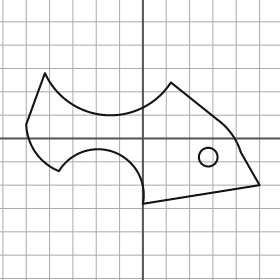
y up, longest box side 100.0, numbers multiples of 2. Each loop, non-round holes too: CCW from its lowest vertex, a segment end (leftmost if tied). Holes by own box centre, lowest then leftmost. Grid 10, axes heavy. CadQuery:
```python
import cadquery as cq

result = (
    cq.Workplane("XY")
    .moveTo(0.0, -28.0)
    .lineTo(50.0, -20.0)
    .lineTo(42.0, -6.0)
    .threePointArc((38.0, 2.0), (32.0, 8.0))
    .lineTo(12.0, 24.0)
    .threePointArc((-16.0, 10.0), (-42.0, 28.0))
    .lineTo(-50.0, 6.0)
    .threePointArc((-46.0, -6.0), (-36.0, -14.0))
    .threePointArc((-12.0, -6.0), (0.0, -28.0))
    .close()
    .moveTo(28.0, -8.0)
    .circle(4.0)
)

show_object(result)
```